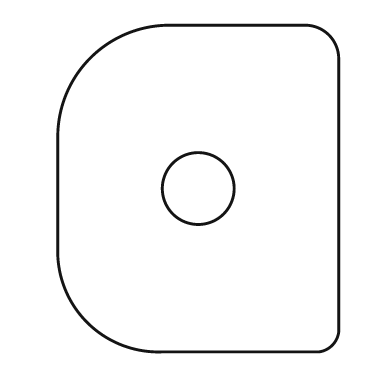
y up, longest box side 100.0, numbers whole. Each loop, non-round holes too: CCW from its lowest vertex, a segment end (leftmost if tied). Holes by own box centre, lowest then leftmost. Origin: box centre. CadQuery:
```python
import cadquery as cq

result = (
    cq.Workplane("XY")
    .moveTo(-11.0, -50.0)
    .lineTo(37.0, -50.0)
    .threePointArc((41.0, -48.0), (43.0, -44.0))
    .lineTo(43.0, 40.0)
    .threePointArc((40.0, 47.0), (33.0, 50.0))
    .lineTo(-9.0, 50.0)
    .threePointArc((-33.0, 40.0), (-43.0, 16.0))
    .lineTo(-43.0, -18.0)
    .threePointArc((-34.0, -41.0), (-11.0, -50.0))
    .close()
    .moveTo(0.0, 0.0)
    .circle(11.0)
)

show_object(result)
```